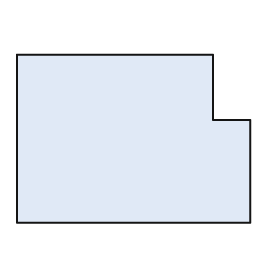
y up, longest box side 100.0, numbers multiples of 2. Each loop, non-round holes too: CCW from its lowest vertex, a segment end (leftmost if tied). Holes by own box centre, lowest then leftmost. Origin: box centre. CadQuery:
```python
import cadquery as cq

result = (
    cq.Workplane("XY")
    .moveTo(-50.0, -36.0)
    .lineTo(50.0, -36.0)
    .lineTo(50.0, 8.0)
    .lineTo(34.0, 8.0)
    .lineTo(34.0, 36.0)
    .lineTo(-50.0, 36.0)
    .close()
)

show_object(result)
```